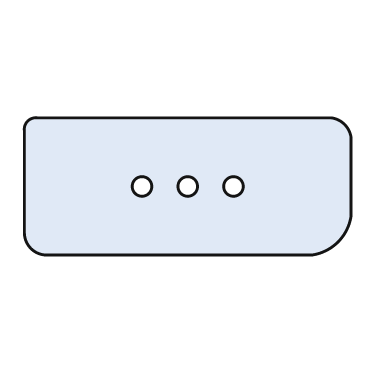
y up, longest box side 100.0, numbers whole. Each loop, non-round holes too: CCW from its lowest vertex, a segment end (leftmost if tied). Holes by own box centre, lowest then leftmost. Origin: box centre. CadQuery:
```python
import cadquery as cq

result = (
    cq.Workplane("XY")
    .moveTo(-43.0, -21.0)
    .lineTo(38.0, -21.0)
    .threePointArc((46.0, -17.0), (50.0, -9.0))
    .lineTo(50.0, 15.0)
    .threePointArc((48.0, 19.0), (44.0, 21.0))
    .lineTo(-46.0, 21.0)
    .threePointArc((-49.0, 20.0), (-50.0, 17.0))
    .lineTo(-50.0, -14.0)
    .threePointArc((-48.0, -19.0), (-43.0, -21.0))
    .close()
    .moveTo(-14.0, 0.0)
    .circle(3.0)
    .moveTo(0.0, 0.0)
    .circle(3.0)
    .moveTo(14.0, 0.0)
    .circle(3.0)
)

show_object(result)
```